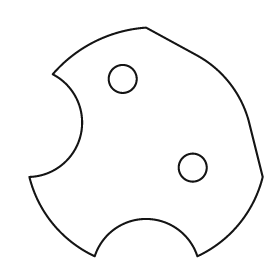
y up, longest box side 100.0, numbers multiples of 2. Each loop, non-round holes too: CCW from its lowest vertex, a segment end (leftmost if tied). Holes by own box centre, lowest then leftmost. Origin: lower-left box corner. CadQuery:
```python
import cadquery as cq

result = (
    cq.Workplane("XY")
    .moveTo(28.0, 0.0)
    .threePointArc((50.0, 16.0), (72.0, 0.0))
    .threePointArc((90.0, 14.0), (100.0, 34.0))
    .lineTo(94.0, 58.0)
    .threePointArc((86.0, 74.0), (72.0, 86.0))
    .lineTo(50.0, 98.0)
    .threePointArc((28.0, 92.0), (10.0, 78.0))
    .threePointArc((22.0, 52.0), (0.0, 34.0))
    .threePointArc((10.0, 14.0), (28.0, 0.0))
    .close()
    .moveTo(70.0, 38.0)
    .circle(6.0)
    .moveTo(40.0, 76.0)
    .circle(6.0)
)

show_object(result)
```